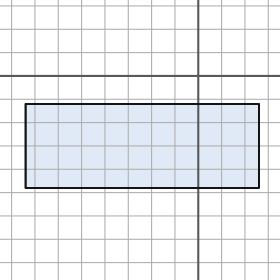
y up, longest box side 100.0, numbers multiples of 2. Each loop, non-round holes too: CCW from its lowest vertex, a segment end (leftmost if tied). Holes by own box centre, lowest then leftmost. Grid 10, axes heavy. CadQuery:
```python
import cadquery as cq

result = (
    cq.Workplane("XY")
    .moveTo(-74.0, -48.0)
    .lineTo(26.0, -48.0)
    .lineTo(26.0, -12.0)
    .lineTo(-74.0, -12.0)
    .close()
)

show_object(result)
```